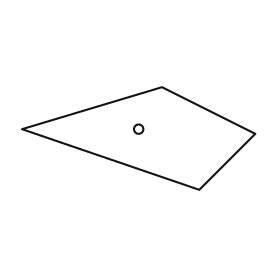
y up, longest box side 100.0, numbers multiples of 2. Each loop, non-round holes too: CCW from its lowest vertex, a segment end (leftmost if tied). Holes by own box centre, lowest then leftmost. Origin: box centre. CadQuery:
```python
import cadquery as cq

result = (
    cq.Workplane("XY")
    .moveTo(26.0, -22.0)
    .lineTo(50.0, 2.0)
    .lineTo(10.0, 22.0)
    .lineTo(-50.0, 4.0)
    .close()
    .moveTo(0.0, 4.0)
    .circle(2.0)
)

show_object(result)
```